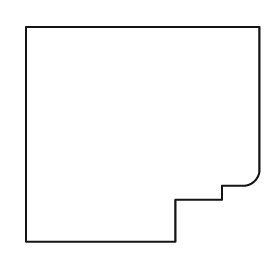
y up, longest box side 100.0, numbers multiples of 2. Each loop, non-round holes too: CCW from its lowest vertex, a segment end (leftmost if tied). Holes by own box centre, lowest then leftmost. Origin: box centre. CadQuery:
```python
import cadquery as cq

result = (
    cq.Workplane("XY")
    .moveTo(-50.0, -46.0)
    .lineTo(14.0, -46.0)
    .lineTo(14.0, -28.0)
    .lineTo(34.0, -28.0)
    .lineTo(34.0, -22.0)
    .lineTo(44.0, -22.0)
    .threePointArc((48.0, -20.0), (50.0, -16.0))
    .lineTo(50.0, 46.0)
    .lineTo(-50.0, 46.0)
    .close()
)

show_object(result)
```